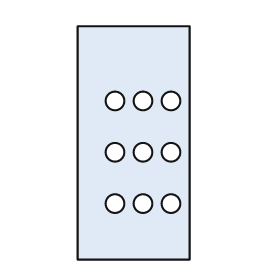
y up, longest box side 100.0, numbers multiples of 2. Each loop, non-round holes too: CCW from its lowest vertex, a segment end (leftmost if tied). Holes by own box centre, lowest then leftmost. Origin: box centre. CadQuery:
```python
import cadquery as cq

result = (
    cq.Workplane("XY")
    .moveTo(-24.0, -50.0)
    .lineTo(24.0, -50.0)
    .lineTo(24.0, 50.0)
    .lineTo(-24.0, 50.0)
    .close()
    .moveTo(-8.0, -26.0)
    .circle(4.0)
    .moveTo(4.0, -26.0)
    .circle(4.0)
    .moveTo(16.0, -26.0)
    .circle(4.0)
    .moveTo(-8.0, -4.0)
    .circle(4.0)
    .moveTo(4.0, -4.0)
    .circle(4.0)
    .moveTo(16.0, -4.0)
    .circle(4.0)
    .moveTo(-8.0, 18.0)
    .circle(4.0)
    .moveTo(4.0, 18.0)
    .circle(4.0)
    .moveTo(16.0, 18.0)
    .circle(4.0)
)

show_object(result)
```